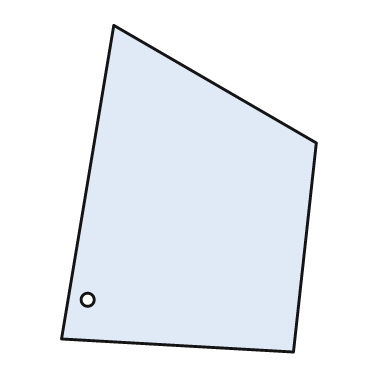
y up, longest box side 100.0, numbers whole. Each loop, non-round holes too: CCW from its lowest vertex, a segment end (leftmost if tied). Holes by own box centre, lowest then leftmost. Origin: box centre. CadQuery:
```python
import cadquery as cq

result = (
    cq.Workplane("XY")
    .moveTo(32.0, -50.0)
    .lineTo(39.0, 14.0)
    .lineTo(-23.0, 50.0)
    .lineTo(-39.0, -46.0)
    .close()
    .moveTo(-31.0, -34.0)
    .circle(2.0)
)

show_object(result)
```